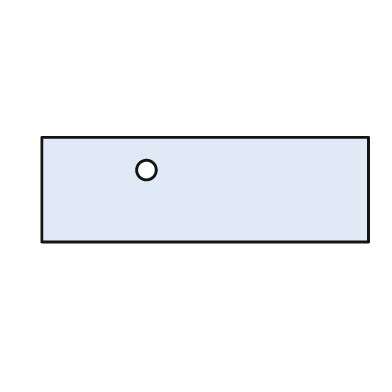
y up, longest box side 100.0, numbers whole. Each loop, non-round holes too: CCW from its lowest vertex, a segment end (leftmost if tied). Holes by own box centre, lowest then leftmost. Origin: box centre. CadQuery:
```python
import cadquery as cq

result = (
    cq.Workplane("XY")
    .moveTo(-50.0, -16.0)
    .lineTo(50.0, -16.0)
    .lineTo(50.0, 16.0)
    .lineTo(-50.0, 16.0)
    .close()
    .moveTo(-18.0, 6.0)
    .circle(3.0)
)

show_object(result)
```